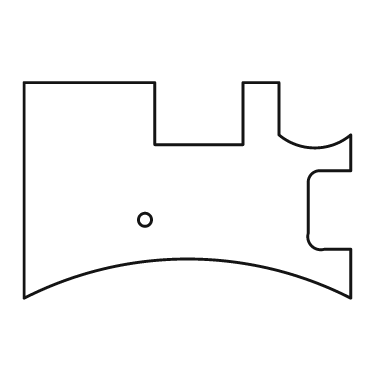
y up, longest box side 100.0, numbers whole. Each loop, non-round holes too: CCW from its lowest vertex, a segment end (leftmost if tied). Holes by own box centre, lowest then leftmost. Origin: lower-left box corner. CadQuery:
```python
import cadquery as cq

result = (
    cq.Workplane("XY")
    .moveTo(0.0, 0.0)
    .threePointArc((50.0, 12.0), (100.0, 0.0))
    .lineTo(100.0, 15.0)
    .lineTo(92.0, 15.0)
    .threePointArc((88.0, 16.0), (87.0, 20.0))
    .lineTo(87.0, 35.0)
    .threePointArc((88.0, 38.0), (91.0, 39.0))
    .lineTo(100.0, 39.0)
    .lineTo(100.0, 50.0)
    .threePointArc((89.0, 46.0), (78.0, 50.0))
    .lineTo(78.0, 66.0)
    .lineTo(67.0, 66.0)
    .lineTo(67.0, 47.0)
    .lineTo(40.0, 47.0)
    .lineTo(40.0, 66.0)
    .lineTo(0.0, 66.0)
    .close()
    .moveTo(37.0, 24.0)
    .circle(2.0)
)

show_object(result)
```